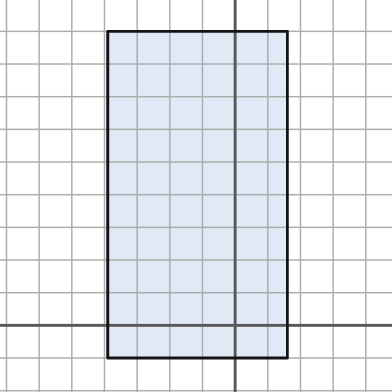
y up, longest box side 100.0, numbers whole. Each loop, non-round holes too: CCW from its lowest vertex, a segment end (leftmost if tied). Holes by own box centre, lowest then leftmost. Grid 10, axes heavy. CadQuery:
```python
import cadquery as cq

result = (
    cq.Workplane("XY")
    .moveTo(-39.0, -10.0)
    .lineTo(16.0, -10.0)
    .lineTo(16.0, 90.0)
    .lineTo(-39.0, 90.0)
    .close()
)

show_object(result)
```